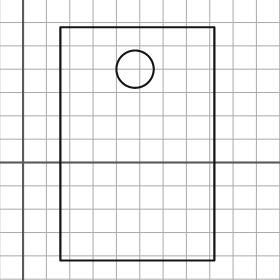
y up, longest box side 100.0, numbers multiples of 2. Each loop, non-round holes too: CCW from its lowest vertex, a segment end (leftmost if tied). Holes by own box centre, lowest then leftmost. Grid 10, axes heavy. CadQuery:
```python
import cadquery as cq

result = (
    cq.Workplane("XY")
    .moveTo(16.0, -42.0)
    .lineTo(82.0, -42.0)
    .lineTo(82.0, 58.0)
    .lineTo(16.0, 58.0)
    .close()
    .moveTo(48.0, 40.0)
    .circle(8.0)
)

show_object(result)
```